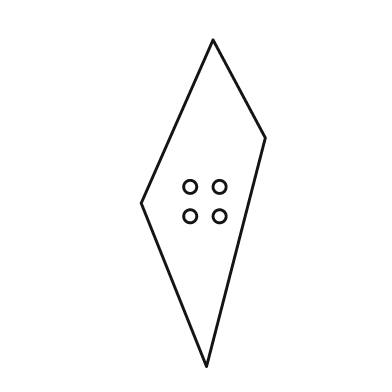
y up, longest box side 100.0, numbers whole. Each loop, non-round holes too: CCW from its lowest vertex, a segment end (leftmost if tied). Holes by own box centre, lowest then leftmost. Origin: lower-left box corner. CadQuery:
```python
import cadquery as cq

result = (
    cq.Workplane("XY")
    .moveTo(20.0, 0.0)
    .lineTo(38.0, 70.0)
    .lineTo(22.0, 100.0)
    .lineTo(0.0, 50.0)
    .close()
    .moveTo(15.0, 46.0)
    .circle(2.0)
    .moveTo(24.0, 46.0)
    .circle(2.0)
    .moveTo(15.0, 55.0)
    .circle(2.0)
    .moveTo(24.0, 55.0)
    .circle(2.0)
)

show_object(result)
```